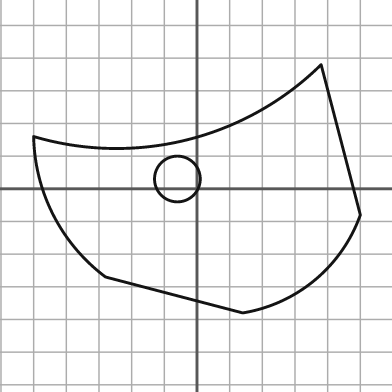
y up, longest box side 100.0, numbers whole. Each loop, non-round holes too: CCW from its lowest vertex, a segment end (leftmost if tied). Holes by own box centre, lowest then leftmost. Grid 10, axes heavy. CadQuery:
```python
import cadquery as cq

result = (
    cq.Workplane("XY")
    .moveTo(14.0, -38.0)
    .threePointArc((36.0, -28.0), (50.0, -8.0))
    .lineTo(38.0, 38.0)
    .threePointArc((-3.0, 15.0), (-50.0, 16.0))
    .threePointArc((-44.0, -8.0), (-28.0, -27.0))
    .close()
    .moveTo(-6.0, 3.0)
    .circle(7.0)
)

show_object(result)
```